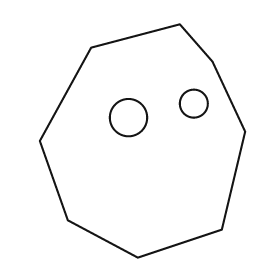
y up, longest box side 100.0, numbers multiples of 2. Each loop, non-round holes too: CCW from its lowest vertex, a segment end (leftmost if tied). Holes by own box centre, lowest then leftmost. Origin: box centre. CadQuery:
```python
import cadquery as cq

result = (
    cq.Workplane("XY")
    .moveTo(-2.0, -50.0)
    .lineTo(34.0, -38.0)
    .lineTo(44.0, 4.0)
    .lineTo(30.0, 34.0)
    .lineTo(16.0, 50.0)
    .lineTo(-22.0, 40.0)
    .lineTo(-44.0, 0.0)
    .lineTo(-32.0, -34.0)
    .close()
    .moveTo(-6.0, 10.0)
    .circle(8.0)
    .moveTo(22.0, 16.0)
    .circle(6.0)
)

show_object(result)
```